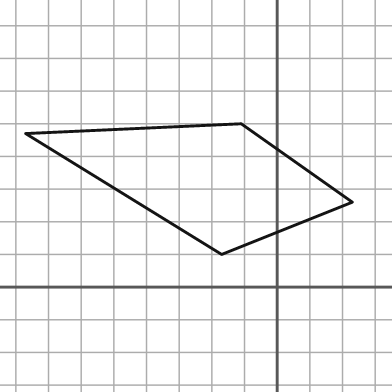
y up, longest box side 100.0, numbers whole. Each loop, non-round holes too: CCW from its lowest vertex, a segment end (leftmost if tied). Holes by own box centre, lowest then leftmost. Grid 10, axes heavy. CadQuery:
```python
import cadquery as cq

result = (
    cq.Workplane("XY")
    .moveTo(-17.0, 10.0)
    .lineTo(23.0, 26.0)
    .lineTo(-11.0, 50.0)
    .lineTo(-77.0, 47.0)
    .close()
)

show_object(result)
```